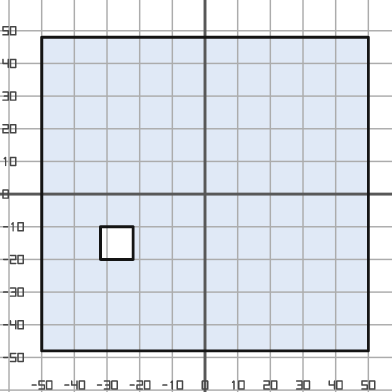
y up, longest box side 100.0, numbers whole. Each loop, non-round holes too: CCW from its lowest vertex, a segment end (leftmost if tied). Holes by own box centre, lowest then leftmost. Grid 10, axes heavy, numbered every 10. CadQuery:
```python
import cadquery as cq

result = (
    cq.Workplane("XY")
    .moveTo(-50.0, -48.0)
    .lineTo(50.0, -48.0)
    .lineTo(50.0, 48.0)
    .lineTo(-50.0, 48.0)
    .close()
    .moveTo(-32.0, -20.0)
    .lineTo(-22.0, -20.0)
    .lineTo(-22.0, -10.0)
    .lineTo(-32.0, -10.0)
    .close()
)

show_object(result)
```